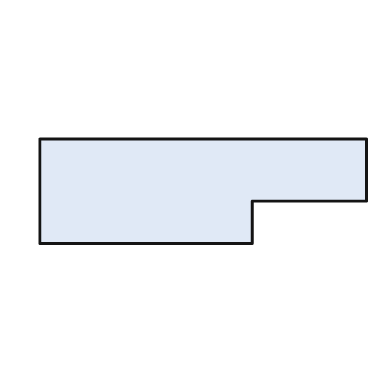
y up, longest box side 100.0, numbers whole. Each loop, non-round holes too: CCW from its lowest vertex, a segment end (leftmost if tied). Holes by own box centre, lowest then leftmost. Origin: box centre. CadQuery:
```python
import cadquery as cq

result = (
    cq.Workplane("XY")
    .moveTo(-50.0, -16.0)
    .lineTo(15.0, -16.0)
    .lineTo(15.0, -3.0)
    .lineTo(50.0, -3.0)
    .lineTo(50.0, 16.0)
    .lineTo(-50.0, 16.0)
    .close()
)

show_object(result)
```